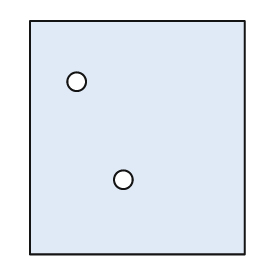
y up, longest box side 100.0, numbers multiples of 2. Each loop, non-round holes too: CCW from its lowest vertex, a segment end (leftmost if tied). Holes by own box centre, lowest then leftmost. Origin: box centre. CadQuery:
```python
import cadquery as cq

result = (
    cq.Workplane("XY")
    .moveTo(-46.0, -50.0)
    .lineTo(46.0, -50.0)
    .lineTo(46.0, 50.0)
    .lineTo(-46.0, 50.0)
    .close()
    .moveTo(-6.0, -18.0)
    .circle(4.0)
    .moveTo(-26.0, 24.0)
    .circle(4.0)
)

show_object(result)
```